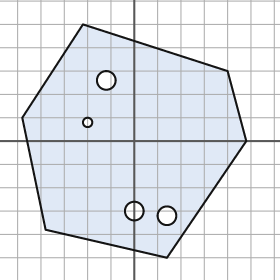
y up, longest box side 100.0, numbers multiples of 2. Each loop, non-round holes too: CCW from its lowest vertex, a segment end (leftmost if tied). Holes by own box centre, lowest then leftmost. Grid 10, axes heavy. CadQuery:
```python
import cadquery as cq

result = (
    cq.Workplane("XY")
    .moveTo(14.0, -50.0)
    .lineTo(48.0, 0.0)
    .lineTo(40.0, 30.0)
    .lineTo(-22.0, 50.0)
    .lineTo(-48.0, 10.0)
    .lineTo(-38.0, -38.0)
    .close()
    .moveTo(14.0, -32.0)
    .circle(4.0)
    .moveTo(0.0, -30.0)
    .circle(4.0)
    .moveTo(-20.0, 8.0)
    .circle(2.0)
    .moveTo(-12.0, 26.0)
    .circle(4.0)
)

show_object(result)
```